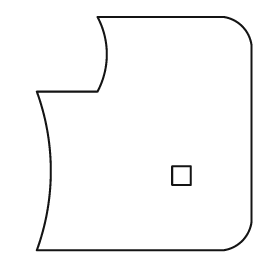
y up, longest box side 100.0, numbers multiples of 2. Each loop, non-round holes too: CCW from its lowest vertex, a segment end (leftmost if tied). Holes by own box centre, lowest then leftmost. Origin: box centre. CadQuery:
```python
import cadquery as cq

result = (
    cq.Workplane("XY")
    .moveTo(-46.0, -50.0)
    .lineTo(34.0, -50.0)
    .threePointArc((42.0, -46.0), (46.0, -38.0))
    .lineTo(46.0, 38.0)
    .threePointArc((42.0, 46.0), (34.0, 50.0))
    .lineTo(-20.0, 50.0)
    .threePointArc((-16.0, 34.0), (-20.0, 18.0))
    .lineTo(-46.0, 18.0)
    .threePointArc((-40.0, -16.0), (-46.0, -50.0))
    .close()
    .moveTo(12.0, -22.0)
    .lineTo(20.0, -22.0)
    .lineTo(20.0, -14.0)
    .lineTo(12.0, -14.0)
    .close()
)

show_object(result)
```